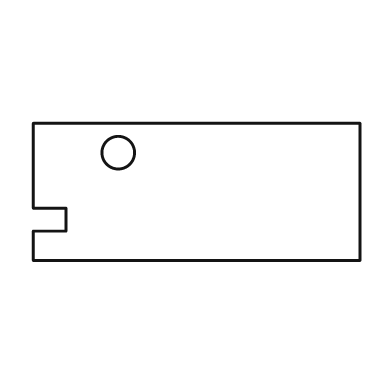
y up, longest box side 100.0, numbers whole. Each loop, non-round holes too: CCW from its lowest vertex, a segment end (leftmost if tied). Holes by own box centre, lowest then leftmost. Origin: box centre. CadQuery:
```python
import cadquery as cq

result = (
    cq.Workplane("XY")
    .moveTo(-50.0, -21.0)
    .lineTo(50.0, -21.0)
    .lineTo(50.0, 21.0)
    .lineTo(-50.0, 21.0)
    .lineTo(-50.0, -5.0)
    .lineTo(-40.0, -5.0)
    .lineTo(-40.0, -12.0)
    .lineTo(-50.0, -12.0)
    .close()
    .moveTo(-24.0, 12.0)
    .circle(5.0)
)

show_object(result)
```